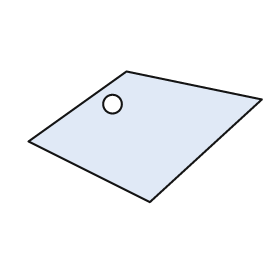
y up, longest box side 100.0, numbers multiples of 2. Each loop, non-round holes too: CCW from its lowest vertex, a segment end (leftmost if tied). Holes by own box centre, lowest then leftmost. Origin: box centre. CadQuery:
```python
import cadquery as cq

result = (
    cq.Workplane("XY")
    .moveTo(2.0, -28.0)
    .lineTo(50.0, 16.0)
    .lineTo(-8.0, 28.0)
    .lineTo(-50.0, -2.0)
    .close()
    .moveTo(-14.0, 14.0)
    .circle(4.0)
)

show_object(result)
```